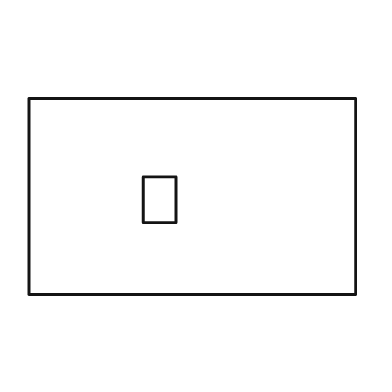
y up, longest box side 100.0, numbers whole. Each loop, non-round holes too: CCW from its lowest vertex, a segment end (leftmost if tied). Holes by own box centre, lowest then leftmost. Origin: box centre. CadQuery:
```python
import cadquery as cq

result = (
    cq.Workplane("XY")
    .moveTo(-50.0, -30.0)
    .lineTo(50.0, -30.0)
    .lineTo(50.0, 30.0)
    .lineTo(-50.0, 30.0)
    .close()
    .moveTo(-15.0, -8.0)
    .lineTo(-5.0, -8.0)
    .lineTo(-5.0, 6.0)
    .lineTo(-15.0, 6.0)
    .close()
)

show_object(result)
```